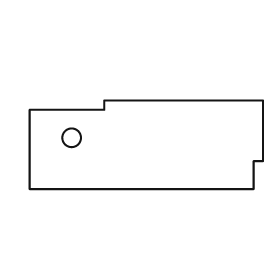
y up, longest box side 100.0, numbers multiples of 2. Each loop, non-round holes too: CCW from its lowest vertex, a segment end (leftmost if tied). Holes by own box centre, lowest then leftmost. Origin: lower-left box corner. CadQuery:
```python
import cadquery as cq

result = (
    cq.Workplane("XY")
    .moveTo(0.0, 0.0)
    .lineTo(96.0, 0.0)
    .lineTo(96.0, 12.0)
    .lineTo(100.0, 12.0)
    .lineTo(100.0, 38.0)
    .lineTo(32.0, 38.0)
    .lineTo(32.0, 34.0)
    .lineTo(0.0, 34.0)
    .close()
    .moveTo(18.0, 22.0)
    .circle(4.0)
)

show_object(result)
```